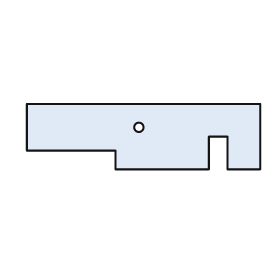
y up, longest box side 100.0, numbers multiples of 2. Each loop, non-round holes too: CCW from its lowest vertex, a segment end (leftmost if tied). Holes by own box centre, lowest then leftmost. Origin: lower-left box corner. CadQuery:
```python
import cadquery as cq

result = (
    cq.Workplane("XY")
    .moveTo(38.0, 0.0)
    .lineTo(78.0, 0.0)
    .lineTo(78.0, 14.0)
    .lineTo(86.0, 14.0)
    .lineTo(86.0, 0.0)
    .lineTo(100.0, 0.0)
    .lineTo(100.0, 28.0)
    .lineTo(0.0, 28.0)
    .lineTo(0.0, 8.0)
    .lineTo(38.0, 8.0)
    .close()
    .moveTo(48.0, 18.0)
    .circle(2.0)
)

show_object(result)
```